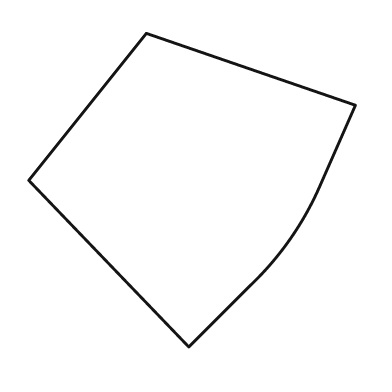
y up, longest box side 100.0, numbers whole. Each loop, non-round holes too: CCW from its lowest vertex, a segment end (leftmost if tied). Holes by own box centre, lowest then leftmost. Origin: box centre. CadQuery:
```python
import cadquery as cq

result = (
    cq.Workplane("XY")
    .moveTo(-1.0, -48.0)
    .lineTo(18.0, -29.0)
    .threePointArc((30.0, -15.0), (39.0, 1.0))
    .lineTo(50.0, 26.0)
    .lineTo(-14.0, 48.0)
    .lineTo(-50.0, 3.0)
    .close()
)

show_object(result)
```